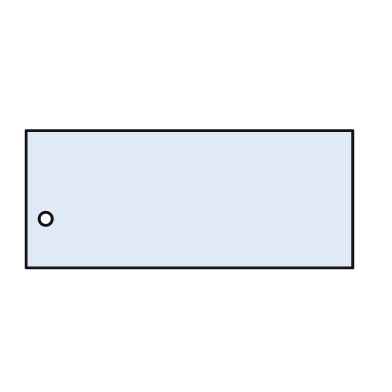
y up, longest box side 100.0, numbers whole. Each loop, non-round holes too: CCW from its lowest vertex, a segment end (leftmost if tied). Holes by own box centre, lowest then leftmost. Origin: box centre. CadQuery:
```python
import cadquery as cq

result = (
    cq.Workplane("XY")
    .moveTo(-50.0, -21.0)
    .lineTo(50.0, -21.0)
    .lineTo(50.0, 21.0)
    .lineTo(-50.0, 21.0)
    .close()
    .moveTo(-44.0, -6.0)
    .circle(2.0)
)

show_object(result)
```